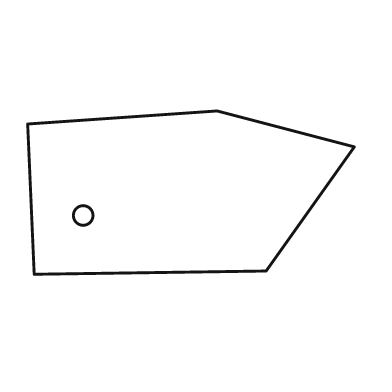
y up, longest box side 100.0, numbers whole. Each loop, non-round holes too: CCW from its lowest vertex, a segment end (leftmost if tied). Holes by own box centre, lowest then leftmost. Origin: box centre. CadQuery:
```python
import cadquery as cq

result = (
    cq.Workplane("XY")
    .moveTo(-48.0, -25.0)
    .lineTo(23.0, -24.0)
    .lineTo(50.0, 14.0)
    .lineTo(8.0, 25.0)
    .lineTo(-50.0, 21.0)
    .close()
    .moveTo(-33.0, -7.0)
    .circle(3.0)
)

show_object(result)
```